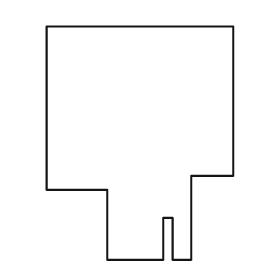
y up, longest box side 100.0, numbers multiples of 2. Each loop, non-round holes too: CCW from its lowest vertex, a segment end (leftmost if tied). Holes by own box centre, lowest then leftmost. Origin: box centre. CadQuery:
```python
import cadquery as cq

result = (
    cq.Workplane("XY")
    .moveTo(-14.0, -50.0)
    .lineTo(10.0, -50.0)
    .lineTo(10.0, -32.0)
    .lineTo(14.0, -32.0)
    .lineTo(14.0, -50.0)
    .lineTo(22.0, -50.0)
    .lineTo(22.0, -14.0)
    .lineTo(40.0, -14.0)
    .lineTo(40.0, 50.0)
    .lineTo(-40.0, 50.0)
    .lineTo(-40.0, -20.0)
    .lineTo(-14.0, -20.0)
    .close()
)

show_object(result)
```